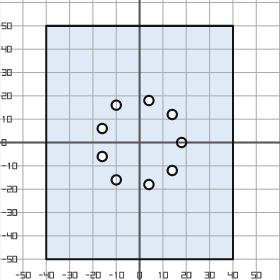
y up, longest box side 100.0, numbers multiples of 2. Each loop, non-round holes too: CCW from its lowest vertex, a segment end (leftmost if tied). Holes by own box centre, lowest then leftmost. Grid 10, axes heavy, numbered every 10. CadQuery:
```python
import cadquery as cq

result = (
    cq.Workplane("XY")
    .moveTo(-40.0, -50.0)
    .lineTo(40.0, -50.0)
    .lineTo(40.0, 50.0)
    .lineTo(-40.0, 50.0)
    .close()
    .moveTo(4.0, -18.0)
    .circle(2.0)
    .moveTo(-10.0, -16.0)
    .circle(2.0)
    .moveTo(14.0, -12.0)
    .circle(2.0)
    .moveTo(-16.0, -6.0)
    .circle(2.0)
    .moveTo(18.0, 0.0)
    .circle(2.0)
    .moveTo(-16.0, 6.0)
    .circle(2.0)
    .moveTo(14.0, 12.0)
    .circle(2.0)
    .moveTo(-10.0, 16.0)
    .circle(2.0)
    .moveTo(4.0, 18.0)
    .circle(2.0)
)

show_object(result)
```